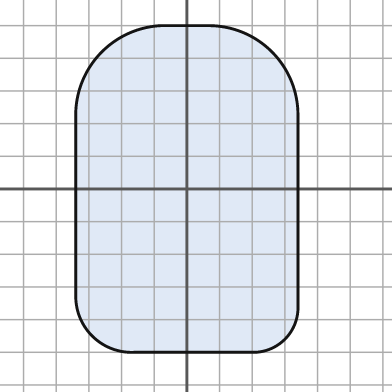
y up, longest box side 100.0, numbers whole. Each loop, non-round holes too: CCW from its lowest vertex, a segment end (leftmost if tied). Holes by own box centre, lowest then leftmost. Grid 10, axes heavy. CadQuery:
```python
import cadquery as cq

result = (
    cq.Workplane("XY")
    .moveTo(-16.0, -50.0)
    .lineTo(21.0, -50.0)
    .threePointArc((30.0, -46.0), (34.0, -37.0))
    .lineTo(34.0, 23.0)
    .threePointArc((26.0, 42.0), (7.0, 50.0))
    .lineTo(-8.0, 50.0)
    .threePointArc((-26.0, 42.0), (-34.0, 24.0))
    .lineTo(-34.0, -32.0)
    .threePointArc((-29.0, -45.0), (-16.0, -50.0))
    .close()
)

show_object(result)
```